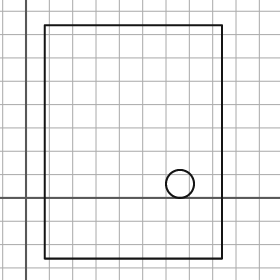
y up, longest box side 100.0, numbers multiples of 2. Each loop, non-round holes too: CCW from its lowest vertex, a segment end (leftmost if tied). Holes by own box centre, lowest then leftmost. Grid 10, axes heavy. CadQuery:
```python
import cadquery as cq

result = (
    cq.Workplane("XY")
    .moveTo(8.0, -26.0)
    .lineTo(84.0, -26.0)
    .lineTo(84.0, 74.0)
    .lineTo(8.0, 74.0)
    .close()
    .moveTo(66.0, 6.0)
    .circle(6.0)
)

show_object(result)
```